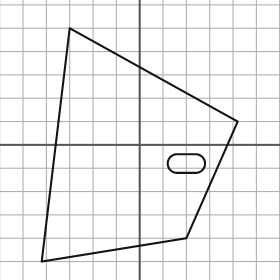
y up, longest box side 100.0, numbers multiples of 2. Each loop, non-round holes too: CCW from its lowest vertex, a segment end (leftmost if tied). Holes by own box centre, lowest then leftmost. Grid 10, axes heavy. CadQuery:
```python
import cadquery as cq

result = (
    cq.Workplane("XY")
    .moveTo(-42.0, -50.0)
    .lineTo(20.0, -40.0)
    .lineTo(42.0, 10.0)
    .lineTo(-30.0, 50.0)
    .close()
    .moveTo(16.0, -12.0)
    .lineTo(24.0, -12.0)
    .threePointArc((28.0, -8.0), (24.0, -4.0))
    .lineTo(16.0, -4.0)
    .threePointArc((12.0, -8.0), (16.0, -12.0))
    .close()
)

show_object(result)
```